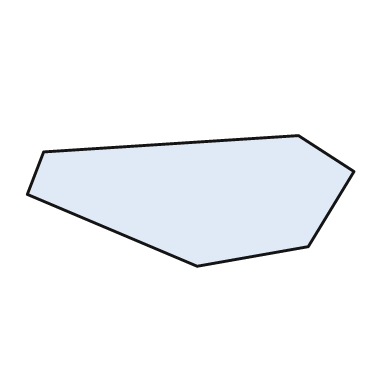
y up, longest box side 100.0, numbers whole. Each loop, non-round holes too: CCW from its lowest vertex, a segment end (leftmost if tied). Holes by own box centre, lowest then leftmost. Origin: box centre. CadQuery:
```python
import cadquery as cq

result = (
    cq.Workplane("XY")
    .moveTo(2.0, -20.0)
    .lineTo(36.0, -14.0)
    .lineTo(50.0, 9.0)
    .lineTo(33.0, 20.0)
    .lineTo(-45.0, 15.0)
    .lineTo(-50.0, 2.0)
    .close()
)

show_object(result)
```